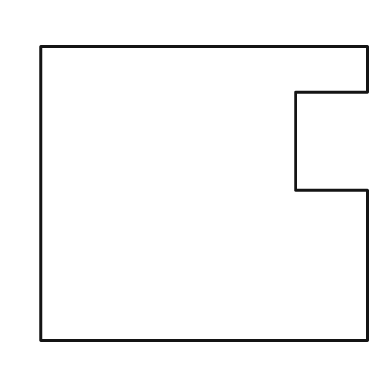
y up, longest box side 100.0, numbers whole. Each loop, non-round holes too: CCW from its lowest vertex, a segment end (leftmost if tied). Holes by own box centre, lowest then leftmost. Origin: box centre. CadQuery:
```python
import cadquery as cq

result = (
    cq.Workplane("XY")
    .moveTo(-50.0, -45.0)
    .lineTo(50.0, -45.0)
    .lineTo(50.0, 1.0)
    .lineTo(28.0, 1.0)
    .lineTo(28.0, 31.0)
    .lineTo(50.0, 31.0)
    .lineTo(50.0, 45.0)
    .lineTo(-50.0, 45.0)
    .close()
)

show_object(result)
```